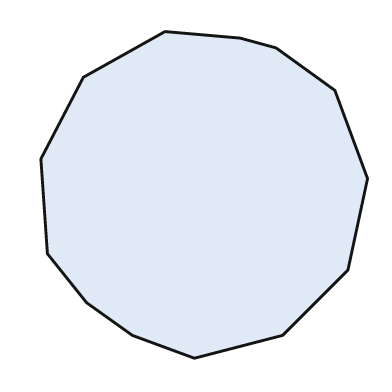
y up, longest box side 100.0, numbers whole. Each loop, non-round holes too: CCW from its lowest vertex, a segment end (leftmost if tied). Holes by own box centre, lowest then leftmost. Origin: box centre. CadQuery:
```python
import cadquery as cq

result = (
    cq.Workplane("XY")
    .moveTo(-3.0, -50.0)
    .lineTo(24.0, -43.0)
    .lineTo(44.0, -23.0)
    .lineTo(50.0, 5.0)
    .lineTo(40.0, 32.0)
    .lineTo(22.0, 45.0)
    .lineTo(11.0, 48.0)
    .lineTo(-12.0, 50.0)
    .lineTo(-37.0, 36.0)
    .lineTo(-50.0, 11.0)
    .lineTo(-48.0, -18.0)
    .lineTo(-36.0, -33.0)
    .lineTo(-22.0, -43.0)
    .close()
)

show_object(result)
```